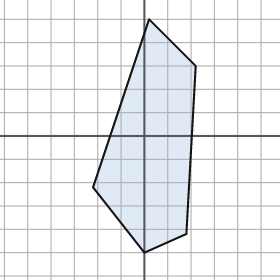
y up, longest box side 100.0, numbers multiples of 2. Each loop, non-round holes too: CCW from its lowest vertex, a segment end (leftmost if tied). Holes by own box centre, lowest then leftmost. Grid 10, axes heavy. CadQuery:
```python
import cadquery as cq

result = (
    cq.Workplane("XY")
    .moveTo(0.0, -50.0)
    .lineTo(18.0, -42.0)
    .lineTo(22.0, 30.0)
    .lineTo(2.0, 50.0)
    .lineTo(-22.0, -22.0)
    .close()
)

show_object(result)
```